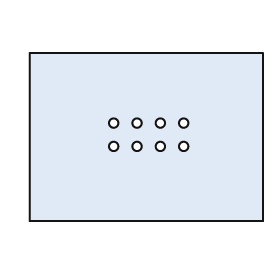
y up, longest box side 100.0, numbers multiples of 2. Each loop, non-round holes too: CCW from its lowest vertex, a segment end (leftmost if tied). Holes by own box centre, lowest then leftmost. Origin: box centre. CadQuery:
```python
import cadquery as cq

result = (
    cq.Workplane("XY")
    .moveTo(-50.0, -36.0)
    .lineTo(50.0, -36.0)
    .lineTo(50.0, 36.0)
    .lineTo(-50.0, 36.0)
    .close()
    .moveTo(-14.0, -4.0)
    .circle(2.0)
    .moveTo(-4.0, -4.0)
    .circle(2.0)
    .moveTo(6.0, -4.0)
    .circle(2.0)
    .moveTo(16.0, -4.0)
    .circle(2.0)
    .moveTo(-14.0, 6.0)
    .circle(2.0)
    .moveTo(-4.0, 6.0)
    .circle(2.0)
    .moveTo(6.0, 6.0)
    .circle(2.0)
    .moveTo(16.0, 6.0)
    .circle(2.0)
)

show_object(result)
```